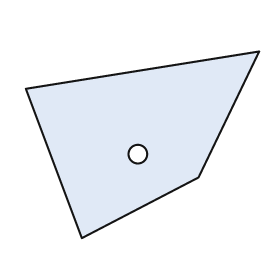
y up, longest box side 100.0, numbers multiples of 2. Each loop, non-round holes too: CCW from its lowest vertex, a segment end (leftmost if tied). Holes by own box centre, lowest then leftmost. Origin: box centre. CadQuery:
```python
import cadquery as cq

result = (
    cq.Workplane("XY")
    .moveTo(-26.0, -40.0)
    .lineTo(24.0, -14.0)
    .lineTo(50.0, 40.0)
    .lineTo(-50.0, 24.0)
    .close()
    .moveTo(-2.0, -4.0)
    .circle(4.0)
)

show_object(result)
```